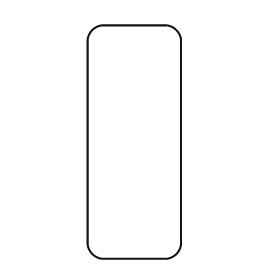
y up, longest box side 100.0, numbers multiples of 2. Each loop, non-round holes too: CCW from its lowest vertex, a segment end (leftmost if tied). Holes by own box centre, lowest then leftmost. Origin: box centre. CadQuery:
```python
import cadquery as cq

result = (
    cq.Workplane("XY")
    .moveTo(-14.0, -50.0)
    .lineTo(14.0, -50.0)
    .threePointArc((18.0, -48.0), (20.0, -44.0))
    .lineTo(20.0, 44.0)
    .threePointArc((18.0, 48.0), (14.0, 50.0))
    .lineTo(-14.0, 50.0)
    .threePointArc((-18.0, 48.0), (-20.0, 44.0))
    .lineTo(-20.0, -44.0)
    .threePointArc((-18.0, -48.0), (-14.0, -50.0))
    .close()
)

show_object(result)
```